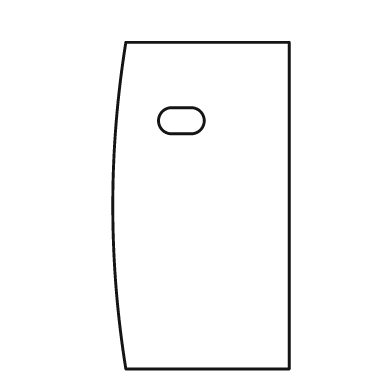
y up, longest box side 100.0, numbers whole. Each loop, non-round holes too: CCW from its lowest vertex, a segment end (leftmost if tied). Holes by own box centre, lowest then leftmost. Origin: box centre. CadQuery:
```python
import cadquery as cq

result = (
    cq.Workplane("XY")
    .moveTo(-23.0, -50.0)
    .lineTo(27.0, -50.0)
    .lineTo(27.0, 50.0)
    .lineTo(-23.0, 50.0)
    .threePointArc((-27.0, 0.0), (-23.0, -50.0))
    .close()
    .moveTo(-9.0, 22.0)
    .lineTo(-3.0, 22.0)
    .threePointArc((1.0, 26.0), (-3.0, 30.0))
    .lineTo(-9.0, 30.0)
    .threePointArc((-13.0, 26.0), (-9.0, 22.0))
    .close()
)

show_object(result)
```